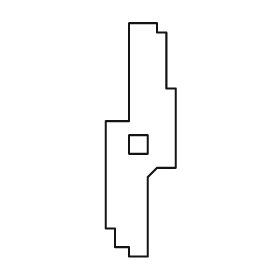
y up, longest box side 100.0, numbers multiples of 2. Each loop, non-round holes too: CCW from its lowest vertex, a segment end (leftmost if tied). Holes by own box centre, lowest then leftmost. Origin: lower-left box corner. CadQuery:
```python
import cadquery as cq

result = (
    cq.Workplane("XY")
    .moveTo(10.0, 0.0)
    .lineTo(18.0, 0.0)
    .lineTo(18.0, 34.0)
    .lineTo(22.0, 38.0)
    .lineTo(30.0, 38.0)
    .lineTo(30.0, 72.0)
    .lineTo(26.0, 72.0)
    .lineTo(26.0, 96.0)
    .lineTo(22.0, 96.0)
    .lineTo(22.0, 100.0)
    .lineTo(10.0, 100.0)
    .lineTo(10.0, 58.0)
    .lineTo(0.0, 58.0)
    .lineTo(0.0, 12.0)
    .lineTo(4.0, 12.0)
    .lineTo(4.0, 4.0)
    .lineTo(10.0, 4.0)
    .close()
    .moveTo(10.0, 44.0)
    .lineTo(18.0, 44.0)
    .lineTo(18.0, 52.0)
    .lineTo(10.0, 52.0)
    .close()
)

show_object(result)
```